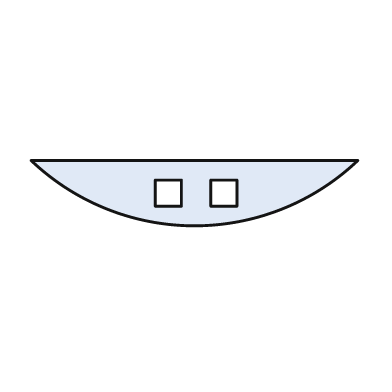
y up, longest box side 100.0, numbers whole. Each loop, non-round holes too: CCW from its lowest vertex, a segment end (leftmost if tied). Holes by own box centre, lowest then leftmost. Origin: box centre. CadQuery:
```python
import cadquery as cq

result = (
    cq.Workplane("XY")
    .moveTo(-50.0, 10.0)
    .threePointArc((0.0, -10.0), (50.0, 10.0))
    .close()
    .moveTo(-12.0, -4.0)
    .lineTo(-4.0, -4.0)
    .lineTo(-4.0, 4.0)
    .lineTo(-12.0, 4.0)
    .close()
    .moveTo(5.0, -4.0)
    .lineTo(13.0, -4.0)
    .lineTo(13.0, 4.0)
    .lineTo(5.0, 4.0)
    .close()
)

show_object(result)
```